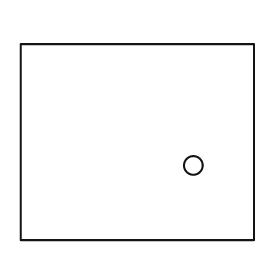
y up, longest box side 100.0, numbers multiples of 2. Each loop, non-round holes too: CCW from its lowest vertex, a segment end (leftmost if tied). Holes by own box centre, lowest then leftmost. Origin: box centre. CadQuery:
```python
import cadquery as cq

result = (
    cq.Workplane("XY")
    .moveTo(-50.0, -42.0)
    .lineTo(50.0, -42.0)
    .lineTo(50.0, 42.0)
    .lineTo(-50.0, 42.0)
    .close()
    .moveTo(24.0, -10.0)
    .circle(4.0)
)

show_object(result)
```